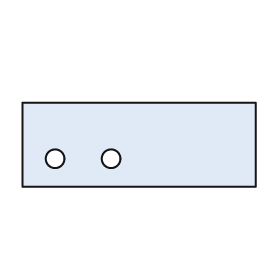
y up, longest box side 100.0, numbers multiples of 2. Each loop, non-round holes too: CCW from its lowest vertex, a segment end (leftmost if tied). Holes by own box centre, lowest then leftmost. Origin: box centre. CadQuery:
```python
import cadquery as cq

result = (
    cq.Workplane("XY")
    .moveTo(-50.0, -18.0)
    .lineTo(50.0, -18.0)
    .lineTo(50.0, 18.0)
    .lineTo(-50.0, 18.0)
    .close()
    .moveTo(-36.0, -6.0)
    .circle(4.0)
    .moveTo(-12.0, -6.0)
    .circle(4.0)
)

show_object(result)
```